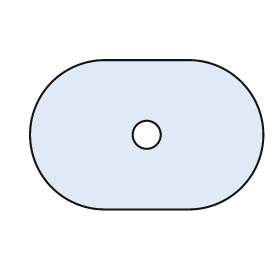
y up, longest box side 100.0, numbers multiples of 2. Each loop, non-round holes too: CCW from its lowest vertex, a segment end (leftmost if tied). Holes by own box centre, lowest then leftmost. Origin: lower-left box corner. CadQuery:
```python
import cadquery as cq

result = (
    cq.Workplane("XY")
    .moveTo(32.0, 0.0)
    .lineTo(68.0, 0.0)
    .threePointArc((100.0, 32.0), (68.0, 64.0))
    .lineTo(32.0, 64.0)
    .threePointArc((0.0, 32.0), (32.0, 0.0))
    .close()
    .moveTo(50.0, 32.0)
    .circle(6.0)
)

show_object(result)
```